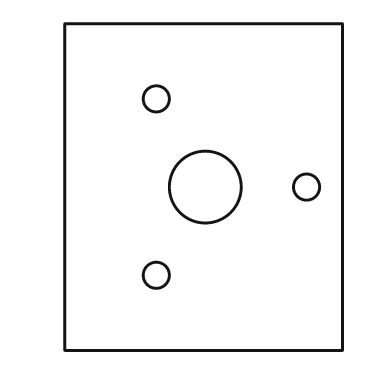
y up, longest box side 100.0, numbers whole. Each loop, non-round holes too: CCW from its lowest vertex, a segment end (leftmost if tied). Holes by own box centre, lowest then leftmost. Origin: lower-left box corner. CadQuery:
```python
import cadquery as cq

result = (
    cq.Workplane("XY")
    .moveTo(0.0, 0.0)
    .lineTo(85.0, 0.0)
    .lineTo(85.0, 100.0)
    .lineTo(0.0, 100.0)
    .close()
    .moveTo(28.0, 23.0)
    .circle(4.0)
    .moveTo(43.0, 50.0)
    .circle(11.0)
    .moveTo(74.0, 50.0)
    .circle(4.0)
    .moveTo(28.0, 77.0)
    .circle(4.0)
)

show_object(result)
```